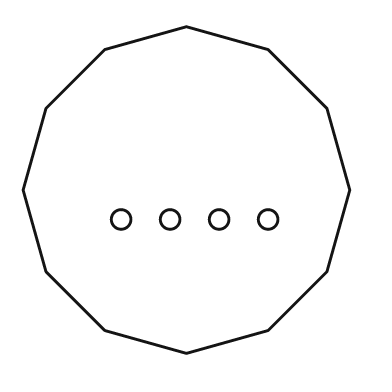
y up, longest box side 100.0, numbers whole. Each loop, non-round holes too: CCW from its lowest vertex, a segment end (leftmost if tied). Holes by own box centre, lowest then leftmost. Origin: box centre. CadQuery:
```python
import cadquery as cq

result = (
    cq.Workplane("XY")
    .moveTo(0.0, -50.0)
    .lineTo(25.0, -43.0)
    .lineTo(43.0, -25.0)
    .lineTo(50.0, 0.0)
    .lineTo(43.0, 25.0)
    .lineTo(25.0, 43.0)
    .lineTo(0.0, 50.0)
    .lineTo(-25.0, 43.0)
    .lineTo(-43.0, 25.0)
    .lineTo(-50.0, 0.0)
    .lineTo(-43.0, -25.0)
    .lineTo(-25.0, -43.0)
    .close()
    .moveTo(-20.0, -9.0)
    .circle(3.0)
    .moveTo(-5.0, -9.0)
    .circle(3.0)
    .moveTo(10.0, -9.0)
    .circle(3.0)
    .moveTo(25.0, -9.0)
    .circle(3.0)
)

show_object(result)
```